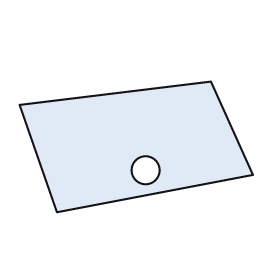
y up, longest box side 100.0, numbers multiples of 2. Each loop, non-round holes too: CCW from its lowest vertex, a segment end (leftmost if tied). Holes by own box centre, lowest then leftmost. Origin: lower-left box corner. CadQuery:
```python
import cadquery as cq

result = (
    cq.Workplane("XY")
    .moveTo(16.0, 0.0)
    .lineTo(100.0, 16.0)
    .lineTo(82.0, 56.0)
    .lineTo(0.0, 46.0)
    .close()
    .moveTo(54.0, 18.0)
    .circle(6.0)
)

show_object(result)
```